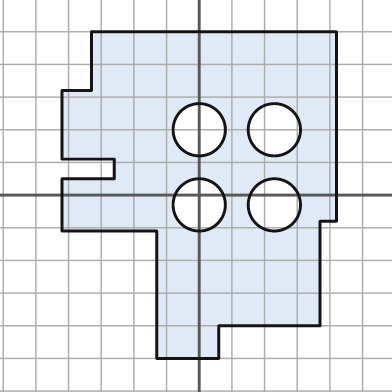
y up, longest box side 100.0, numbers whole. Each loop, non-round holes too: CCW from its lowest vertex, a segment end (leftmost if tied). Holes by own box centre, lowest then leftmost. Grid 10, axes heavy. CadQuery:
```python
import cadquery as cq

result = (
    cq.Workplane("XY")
    .moveTo(-13.0, -50.0)
    .lineTo(6.0, -50.0)
    .lineTo(6.0, -40.0)
    .lineTo(37.0, -40.0)
    .lineTo(37.0, -8.0)
    .lineTo(42.0, -8.0)
    .lineTo(42.0, 50.0)
    .lineTo(-33.0, 50.0)
    .lineTo(-33.0, 32.0)
    .lineTo(-42.0, 32.0)
    .lineTo(-42.0, 11.0)
    .lineTo(-26.0, 11.0)
    .lineTo(-26.0, 5.0)
    .lineTo(-42.0, 5.0)
    .lineTo(-42.0, -11.0)
    .lineTo(-13.0, -11.0)
    .close()
    .moveTo(0.0, -3.0)
    .circle(8.0)
    .moveTo(23.0, -3.0)
    .circle(8.0)
    .moveTo(0.0, 20.0)
    .circle(8.0)
    .moveTo(23.0, 20.0)
    .circle(8.0)
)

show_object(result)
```